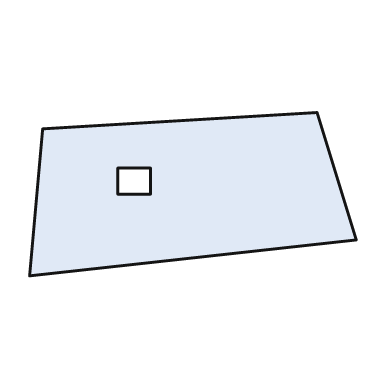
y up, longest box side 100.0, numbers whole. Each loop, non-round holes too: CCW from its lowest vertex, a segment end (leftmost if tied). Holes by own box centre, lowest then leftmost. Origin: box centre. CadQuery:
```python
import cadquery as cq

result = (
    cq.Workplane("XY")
    .moveTo(-50.0, -25.0)
    .lineTo(50.0, -14.0)
    .lineTo(38.0, 25.0)
    .lineTo(-46.0, 20.0)
    .close()
    .moveTo(-23.0, 0.0)
    .lineTo(-13.0, 0.0)
    .lineTo(-13.0, 8.0)
    .lineTo(-23.0, 8.0)
    .close()
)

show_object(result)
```